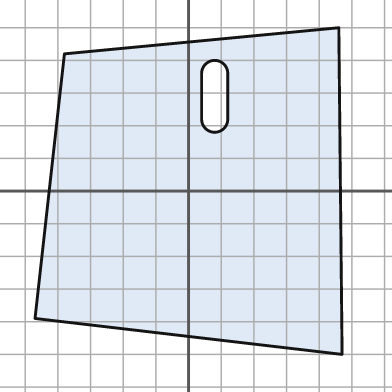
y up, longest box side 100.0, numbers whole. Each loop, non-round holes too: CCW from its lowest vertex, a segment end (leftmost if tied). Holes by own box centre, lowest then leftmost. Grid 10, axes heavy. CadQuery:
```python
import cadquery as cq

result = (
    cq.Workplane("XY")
    .moveTo(47.0, -50.0)
    .lineTo(46.0, 50.0)
    .lineTo(-38.0, 42.0)
    .lineTo(-47.0, -39.0)
    .close()
    .moveTo(4.0, 22.0)
    .threePointArc((8.0, 18.0), (12.0, 22.0))
    .lineTo(12.0, 36.0)
    .threePointArc((8.0, 40.0), (4.0, 36.0))
    .close()
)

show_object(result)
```